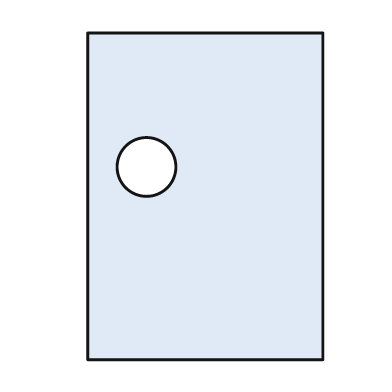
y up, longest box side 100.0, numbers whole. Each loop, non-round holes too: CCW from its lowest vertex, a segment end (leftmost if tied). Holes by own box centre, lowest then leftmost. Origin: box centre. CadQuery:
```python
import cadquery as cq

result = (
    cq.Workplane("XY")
    .moveTo(-36.0, -50.0)
    .lineTo(36.0, -50.0)
    .lineTo(36.0, 50.0)
    .lineTo(-36.0, 50.0)
    .close()
    .moveTo(-18.0, 9.0)
    .circle(9.0)
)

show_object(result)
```